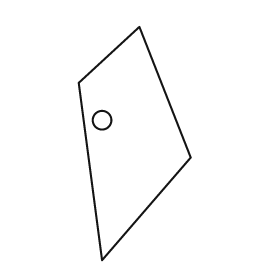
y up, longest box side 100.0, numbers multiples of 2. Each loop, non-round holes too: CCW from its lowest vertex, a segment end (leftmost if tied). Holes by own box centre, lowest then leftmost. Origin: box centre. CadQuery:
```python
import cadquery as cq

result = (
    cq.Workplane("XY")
    .moveTo(-14.0, -50.0)
    .lineTo(24.0, -6.0)
    .lineTo(2.0, 50.0)
    .lineTo(-24.0, 26.0)
    .close()
    .moveTo(-14.0, 10.0)
    .circle(4.0)
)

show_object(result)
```